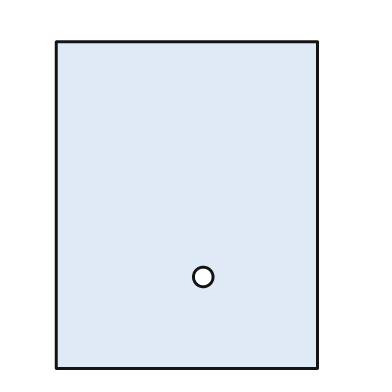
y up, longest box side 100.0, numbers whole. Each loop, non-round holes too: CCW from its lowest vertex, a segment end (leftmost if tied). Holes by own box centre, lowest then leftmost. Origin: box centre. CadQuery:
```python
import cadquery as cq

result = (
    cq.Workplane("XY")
    .moveTo(-40.0, -50.0)
    .lineTo(40.0, -50.0)
    .lineTo(40.0, 50.0)
    .lineTo(-40.0, 50.0)
    .close()
    .moveTo(5.0, -22.0)
    .circle(3.0)
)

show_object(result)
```